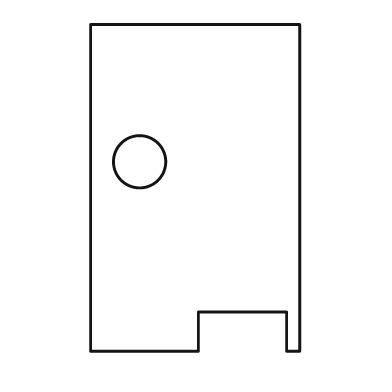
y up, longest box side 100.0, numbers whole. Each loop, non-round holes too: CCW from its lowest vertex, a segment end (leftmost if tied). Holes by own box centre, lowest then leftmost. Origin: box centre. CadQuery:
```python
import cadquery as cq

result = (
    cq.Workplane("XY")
    .moveTo(-32.0, -50.0)
    .lineTo(1.0, -50.0)
    .lineTo(1.0, -38.0)
    .lineTo(28.0, -38.0)
    .lineTo(28.0, -50.0)
    .lineTo(32.0, -50.0)
    .lineTo(32.0, 50.0)
    .lineTo(-32.0, 50.0)
    .close()
    .moveTo(-17.0, 8.0)
    .circle(8.0)
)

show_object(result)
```